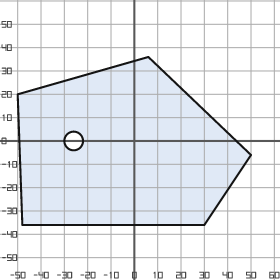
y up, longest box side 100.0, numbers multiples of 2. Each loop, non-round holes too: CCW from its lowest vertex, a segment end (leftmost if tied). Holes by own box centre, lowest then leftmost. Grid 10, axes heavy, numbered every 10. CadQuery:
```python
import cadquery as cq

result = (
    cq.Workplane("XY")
    .moveTo(-48.0, -36.0)
    .lineTo(30.0, -36.0)
    .lineTo(50.0, -6.0)
    .lineTo(6.0, 36.0)
    .lineTo(-50.0, 20.0)
    .close()
    .moveTo(-26.0, 0.0)
    .circle(4.0)
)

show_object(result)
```